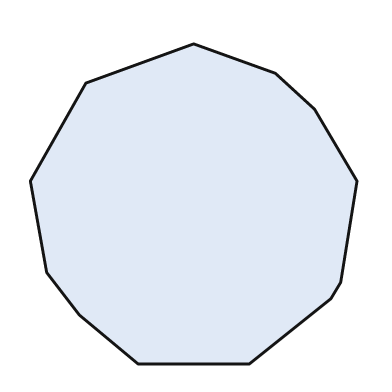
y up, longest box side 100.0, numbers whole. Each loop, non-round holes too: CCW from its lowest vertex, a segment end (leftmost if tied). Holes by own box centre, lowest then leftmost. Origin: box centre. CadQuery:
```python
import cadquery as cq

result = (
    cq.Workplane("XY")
    .moveTo(-17.0, -49.0)
    .lineTo(17.0, -49.0)
    .lineTo(42.0, -29.0)
    .lineTo(45.0, -24.0)
    .lineTo(50.0, 7.0)
    .lineTo(37.0, 29.0)
    .lineTo(25.0, 40.0)
    .lineTo(0.0, 49.0)
    .lineTo(-33.0, 37.0)
    .lineTo(-50.0, 7.0)
    .lineTo(-45.0, -21.0)
    .lineTo(-35.0, -34.0)
    .close()
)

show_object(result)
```